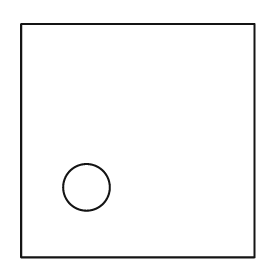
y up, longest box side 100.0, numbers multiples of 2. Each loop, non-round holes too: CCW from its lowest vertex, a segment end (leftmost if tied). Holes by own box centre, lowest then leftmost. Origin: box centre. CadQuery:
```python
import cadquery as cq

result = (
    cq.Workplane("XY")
    .moveTo(-50.0, -50.0)
    .lineTo(50.0, -50.0)
    .lineTo(50.0, 50.0)
    .lineTo(-50.0, 50.0)
    .close()
    .moveTo(-22.0, -20.0)
    .circle(10.0)
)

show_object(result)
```